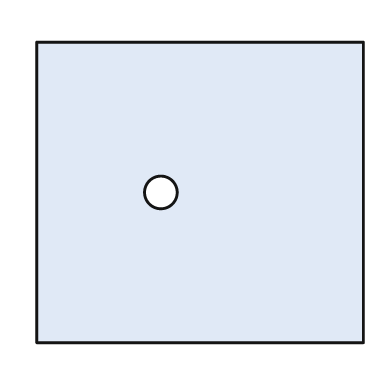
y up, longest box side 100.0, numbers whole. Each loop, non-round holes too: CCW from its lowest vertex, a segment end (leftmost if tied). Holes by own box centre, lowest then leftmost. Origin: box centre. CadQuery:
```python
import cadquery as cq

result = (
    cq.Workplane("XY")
    .moveTo(-50.0, -46.0)
    .lineTo(50.0, -46.0)
    .lineTo(50.0, 46.0)
    .lineTo(-50.0, 46.0)
    .close()
    .moveTo(-12.0, 0.0)
    .circle(5.0)
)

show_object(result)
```